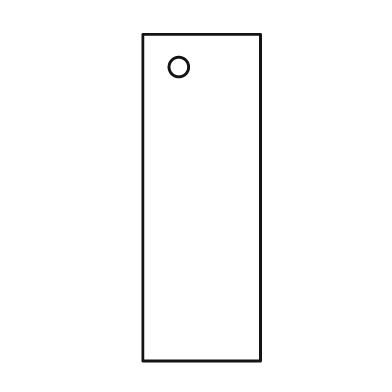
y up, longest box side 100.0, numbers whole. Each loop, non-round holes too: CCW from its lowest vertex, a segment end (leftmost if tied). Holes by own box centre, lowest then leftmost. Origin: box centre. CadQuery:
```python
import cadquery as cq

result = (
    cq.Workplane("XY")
    .moveTo(-18.0, -50.0)
    .lineTo(18.0, -50.0)
    .lineTo(18.0, 50.0)
    .lineTo(-18.0, 50.0)
    .close()
    .moveTo(-7.0, 40.0)
    .circle(3.0)
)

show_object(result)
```